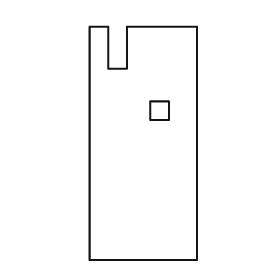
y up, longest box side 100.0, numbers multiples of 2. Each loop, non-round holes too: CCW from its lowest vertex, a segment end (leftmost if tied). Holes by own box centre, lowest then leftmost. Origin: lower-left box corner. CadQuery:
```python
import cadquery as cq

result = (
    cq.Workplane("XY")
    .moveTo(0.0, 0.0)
    .lineTo(46.0, 0.0)
    .lineTo(46.0, 100.0)
    .lineTo(16.0, 100.0)
    .lineTo(16.0, 82.0)
    .lineTo(8.0, 82.0)
    .lineTo(8.0, 100.0)
    .lineTo(0.0, 100.0)
    .close()
    .moveTo(26.0, 60.0)
    .lineTo(34.0, 60.0)
    .lineTo(34.0, 68.0)
    .lineTo(26.0, 68.0)
    .close()
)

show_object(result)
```